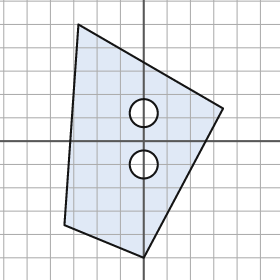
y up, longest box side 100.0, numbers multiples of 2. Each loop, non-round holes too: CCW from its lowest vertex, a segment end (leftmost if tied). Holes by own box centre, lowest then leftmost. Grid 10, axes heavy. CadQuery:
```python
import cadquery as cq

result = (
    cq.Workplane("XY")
    .moveTo(0.0, -50.0)
    .lineTo(34.0, 14.0)
    .lineTo(-28.0, 50.0)
    .lineTo(-34.0, -36.0)
    .close()
    .moveTo(0.0, -10.0)
    .circle(6.0)
    .moveTo(0.0, 12.0)
    .circle(6.0)
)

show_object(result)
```